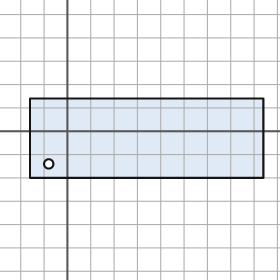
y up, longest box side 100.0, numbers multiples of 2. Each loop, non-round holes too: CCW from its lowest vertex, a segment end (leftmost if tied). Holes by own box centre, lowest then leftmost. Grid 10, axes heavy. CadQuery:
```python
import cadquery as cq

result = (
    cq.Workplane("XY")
    .moveTo(-16.0, -20.0)
    .lineTo(84.0, -20.0)
    .lineTo(84.0, 14.0)
    .lineTo(-16.0, 14.0)
    .close()
    .moveTo(-8.0, -14.0)
    .circle(2.0)
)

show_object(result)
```